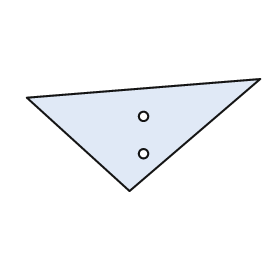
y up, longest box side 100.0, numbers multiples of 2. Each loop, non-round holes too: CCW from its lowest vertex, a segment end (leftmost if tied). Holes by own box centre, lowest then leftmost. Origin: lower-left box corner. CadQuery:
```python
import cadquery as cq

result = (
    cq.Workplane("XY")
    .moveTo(44.0, 0.0)
    .lineTo(100.0, 48.0)
    .lineTo(0.0, 40.0)
    .close()
    .moveTo(50.0, 16.0)
    .circle(2.0)
    .moveTo(50.0, 32.0)
    .circle(2.0)
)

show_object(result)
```